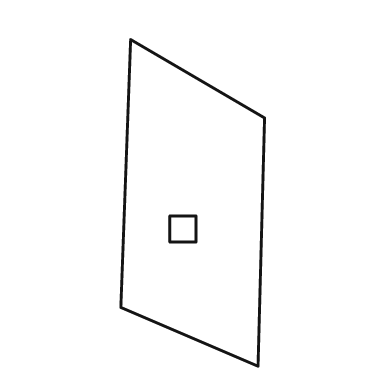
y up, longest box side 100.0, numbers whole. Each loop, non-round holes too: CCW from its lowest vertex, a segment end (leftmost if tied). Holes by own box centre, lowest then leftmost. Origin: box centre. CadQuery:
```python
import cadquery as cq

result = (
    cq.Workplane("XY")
    .moveTo(20.0, -50.0)
    .lineTo(22.0, 26.0)
    .lineTo(-19.0, 50.0)
    .lineTo(-22.0, -32.0)
    .close()
    .moveTo(-7.0, -12.0)
    .lineTo(1.0, -12.0)
    .lineTo(1.0, -4.0)
    .lineTo(-7.0, -4.0)
    .close()
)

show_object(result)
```